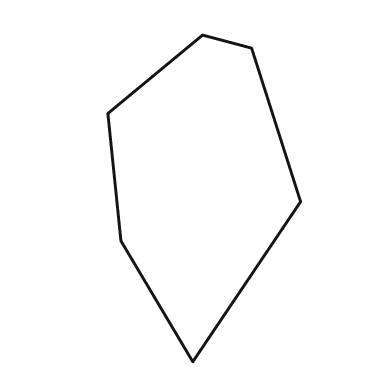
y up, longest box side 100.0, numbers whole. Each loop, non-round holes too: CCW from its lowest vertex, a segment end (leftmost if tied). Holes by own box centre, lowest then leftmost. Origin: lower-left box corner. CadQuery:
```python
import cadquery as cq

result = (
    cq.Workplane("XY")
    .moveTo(26.0, 0.0)
    .lineTo(59.0, 49.0)
    .lineTo(44.0, 96.0)
    .lineTo(29.0, 100.0)
    .lineTo(0.0, 76.0)
    .lineTo(4.0, 37.0)
    .close()
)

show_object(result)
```